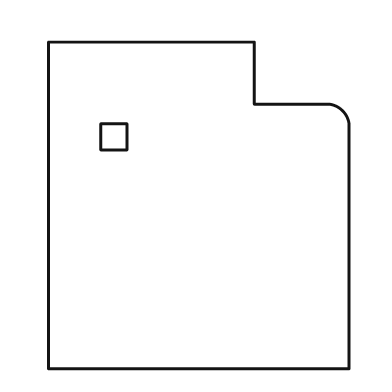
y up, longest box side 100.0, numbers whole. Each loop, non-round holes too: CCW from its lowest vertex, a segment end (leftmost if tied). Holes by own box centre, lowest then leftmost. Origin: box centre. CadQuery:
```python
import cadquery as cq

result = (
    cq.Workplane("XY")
    .moveTo(-46.0, -50.0)
    .lineTo(46.0, -50.0)
    .lineTo(46.0, 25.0)
    .threePointArc((44.0, 29.0), (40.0, 31.0))
    .lineTo(17.0, 31.0)
    .lineTo(17.0, 50.0)
    .lineTo(-46.0, 50.0)
    .close()
    .moveTo(-30.0, 17.0)
    .lineTo(-22.0, 17.0)
    .lineTo(-22.0, 25.0)
    .lineTo(-30.0, 25.0)
    .close()
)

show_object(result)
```